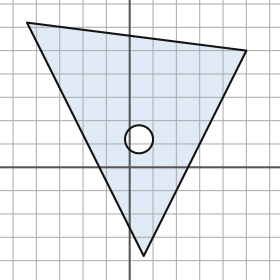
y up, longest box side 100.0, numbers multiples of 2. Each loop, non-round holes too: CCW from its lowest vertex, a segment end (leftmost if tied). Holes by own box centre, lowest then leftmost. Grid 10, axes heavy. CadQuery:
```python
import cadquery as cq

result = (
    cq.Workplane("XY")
    .moveTo(6.0, -38.0)
    .lineTo(50.0, 50.0)
    .lineTo(-44.0, 62.0)
    .close()
    .moveTo(4.0, 12.0)
    .circle(6.0)
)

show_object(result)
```